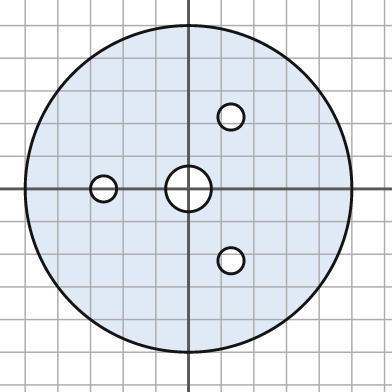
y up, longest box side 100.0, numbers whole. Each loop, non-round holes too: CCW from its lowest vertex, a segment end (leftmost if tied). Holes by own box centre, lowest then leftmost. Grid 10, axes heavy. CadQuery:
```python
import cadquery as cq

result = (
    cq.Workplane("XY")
    .moveTo(0.0, 0.0)
    .circle(50.0)
    .moveTo(13.0, -22.0)
    .circle(4.0)
    .moveTo(-26.0, 0.0)
    .circle(4.0)
    .moveTo(0.0, 0.0)
    .circle(7.0)
    .moveTo(13.0, 22.0)
    .circle(4.0)
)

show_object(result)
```